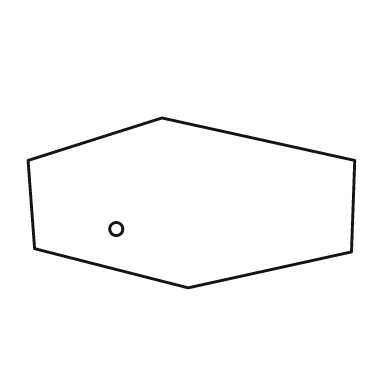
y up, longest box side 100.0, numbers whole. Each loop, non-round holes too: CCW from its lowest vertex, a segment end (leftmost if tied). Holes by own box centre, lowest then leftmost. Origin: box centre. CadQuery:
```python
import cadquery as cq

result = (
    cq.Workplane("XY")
    .moveTo(-1.0, -26.0)
    .lineTo(49.0, -15.0)
    .lineTo(50.0, 13.0)
    .lineTo(-9.0, 26.0)
    .lineTo(-50.0, 13.0)
    .lineTo(-48.0, -14.0)
    .close()
    .moveTo(-23.0, -8.0)
    .circle(2.0)
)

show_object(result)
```